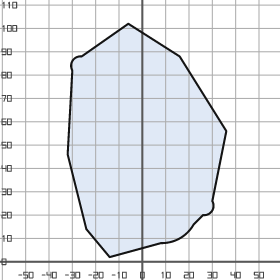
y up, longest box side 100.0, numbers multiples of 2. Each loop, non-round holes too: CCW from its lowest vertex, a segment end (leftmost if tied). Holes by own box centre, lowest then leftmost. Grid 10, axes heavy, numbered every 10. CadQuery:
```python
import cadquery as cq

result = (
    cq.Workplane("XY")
    .moveTo(-14.0, 2.0)
    .lineTo(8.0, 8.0)
    .threePointArc((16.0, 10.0), (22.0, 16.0))
    .lineTo(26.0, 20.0)
    .threePointArc((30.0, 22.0), (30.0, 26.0))
    .lineTo(36.0, 56.0)
    .lineTo(16.0, 88.0)
    .lineTo(-6.0, 102.0)
    .lineTo(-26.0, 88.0)
    .threePointArc((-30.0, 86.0), (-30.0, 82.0))
    .lineTo(-32.0, 46.0)
    .lineTo(-24.0, 14.0)
    .close()
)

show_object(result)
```